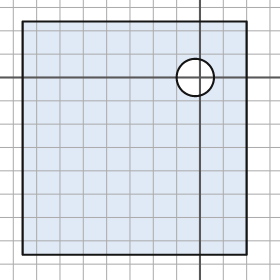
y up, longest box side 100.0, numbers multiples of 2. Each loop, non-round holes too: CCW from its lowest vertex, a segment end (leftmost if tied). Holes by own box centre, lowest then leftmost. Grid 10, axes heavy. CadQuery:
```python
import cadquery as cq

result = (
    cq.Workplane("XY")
    .moveTo(-76.0, -76.0)
    .lineTo(20.0, -76.0)
    .lineTo(20.0, 24.0)
    .lineTo(-76.0, 24.0)
    .close()
    .moveTo(-2.0, 0.0)
    .circle(8.0)
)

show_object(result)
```